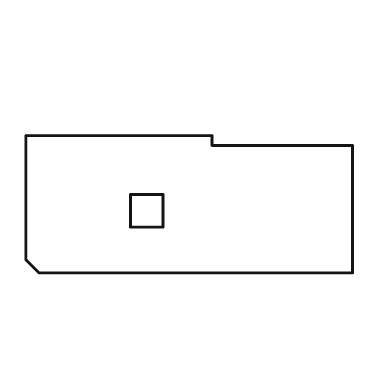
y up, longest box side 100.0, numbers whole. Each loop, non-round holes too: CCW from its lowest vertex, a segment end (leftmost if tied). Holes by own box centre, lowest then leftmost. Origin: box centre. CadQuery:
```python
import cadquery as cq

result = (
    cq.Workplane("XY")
    .moveTo(-46.0, -21.0)
    .lineTo(50.0, -21.0)
    .lineTo(50.0, 18.0)
    .lineTo(7.0, 18.0)
    .lineTo(7.0, 21.0)
    .lineTo(-50.0, 21.0)
    .lineTo(-50.0, -17.0)
    .close()
    .moveTo(-18.0, -7.0)
    .lineTo(-8.0, -7.0)
    .lineTo(-8.0, 3.0)
    .lineTo(-18.0, 3.0)
    .close()
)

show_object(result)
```